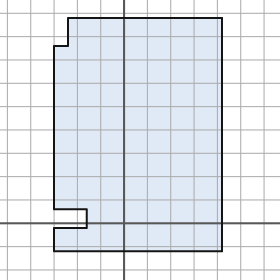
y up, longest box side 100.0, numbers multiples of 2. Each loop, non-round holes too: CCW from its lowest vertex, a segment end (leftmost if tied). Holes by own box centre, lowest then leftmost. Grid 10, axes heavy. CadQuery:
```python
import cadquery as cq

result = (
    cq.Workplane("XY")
    .moveTo(-30.0, -12.0)
    .lineTo(42.0, -12.0)
    .lineTo(42.0, 88.0)
    .lineTo(-24.0, 88.0)
    .lineTo(-24.0, 76.0)
    .lineTo(-30.0, 76.0)
    .lineTo(-30.0, 6.0)
    .lineTo(-16.0, 6.0)
    .lineTo(-16.0, -2.0)
    .lineTo(-30.0, -2.0)
    .close()
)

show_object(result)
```